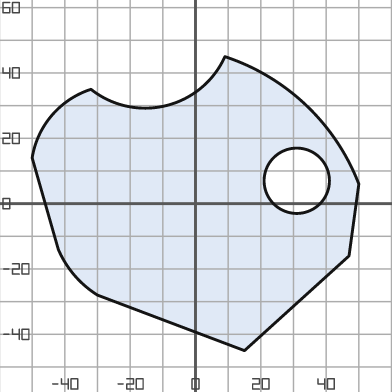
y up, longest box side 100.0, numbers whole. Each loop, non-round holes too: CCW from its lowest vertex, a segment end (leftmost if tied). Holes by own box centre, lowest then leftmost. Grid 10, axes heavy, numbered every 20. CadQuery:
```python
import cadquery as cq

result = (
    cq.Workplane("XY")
    .moveTo(15.0, -45.0)
    .lineTo(47.0, -16.0)
    .lineTo(50.0, 6.0)
    .threePointArc((34.0, 30.0), (9.0, 45.0))
    .threePointArc((-9.0, 30.0), (-32.0, 35.0))
    .threePointArc((-44.0, 27.0), (-50.0, 14.0))
    .lineTo(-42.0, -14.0)
    .threePointArc((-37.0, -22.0), (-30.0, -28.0))
    .close()
    .moveTo(31.0, 7.0)
    .circle(10.0)
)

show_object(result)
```